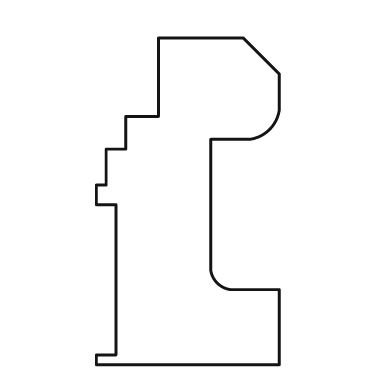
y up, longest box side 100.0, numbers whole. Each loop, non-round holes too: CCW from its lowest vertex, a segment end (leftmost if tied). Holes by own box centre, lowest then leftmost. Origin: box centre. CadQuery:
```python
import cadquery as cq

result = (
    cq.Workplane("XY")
    .moveTo(-28.0, -50.0)
    .lineTo(28.0, -50.0)
    .lineTo(28.0, -27.0)
    .lineTo(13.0, -27.0)
    .threePointArc((9.0, -25.0), (7.0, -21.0))
    .lineTo(7.0, 19.0)
    .lineTo(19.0, 19.0)
    .threePointArc((25.0, 22.0), (28.0, 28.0))
    .lineTo(28.0, 39.0)
    .lineTo(17.0, 50.0)
    .lineTo(-9.0, 50.0)
    .lineTo(-9.0, 26.0)
    .lineTo(-19.0, 26.0)
    .lineTo(-19.0, 16.0)
    .lineTo(-25.0, 16.0)
    .lineTo(-25.0, 5.0)
    .lineTo(-28.0, 5.0)
    .lineTo(-28.0, -1.0)
    .lineTo(-22.0, -1.0)
    .lineTo(-22.0, -47.0)
    .lineTo(-28.0, -47.0)
    .close()
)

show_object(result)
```